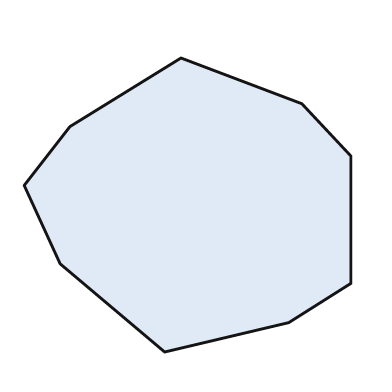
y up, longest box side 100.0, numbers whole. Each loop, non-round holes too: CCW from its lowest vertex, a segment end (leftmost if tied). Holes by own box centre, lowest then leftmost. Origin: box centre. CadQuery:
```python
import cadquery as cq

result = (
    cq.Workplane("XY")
    .moveTo(-7.0, -45.0)
    .lineTo(31.0, -36.0)
    .lineTo(50.0, -24.0)
    .lineTo(50.0, 15.0)
    .lineTo(35.0, 31.0)
    .lineTo(-2.0, 45.0)
    .lineTo(-36.0, 24.0)
    .lineTo(-50.0, 6.0)
    .lineTo(-39.0, -18.0)
    .close()
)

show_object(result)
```